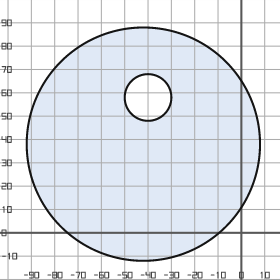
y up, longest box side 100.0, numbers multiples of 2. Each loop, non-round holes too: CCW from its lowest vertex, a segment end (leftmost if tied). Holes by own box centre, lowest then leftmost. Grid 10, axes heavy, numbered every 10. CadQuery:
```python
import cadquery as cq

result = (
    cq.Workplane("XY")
    .moveTo(-42.0, 38.0)
    .circle(50.0)
    .moveTo(-40.0, 58.0)
    .circle(10.0)
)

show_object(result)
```